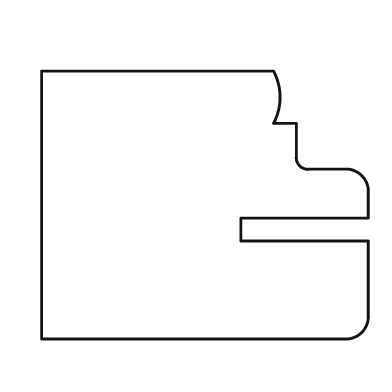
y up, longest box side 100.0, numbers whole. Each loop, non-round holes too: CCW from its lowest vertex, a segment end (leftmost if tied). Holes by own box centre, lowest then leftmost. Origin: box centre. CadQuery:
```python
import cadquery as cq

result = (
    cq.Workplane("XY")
    .moveTo(-50.0, -41.0)
    .lineTo(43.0, -41.0)
    .threePointArc((48.0, -39.0), (50.0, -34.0))
    .lineTo(50.0, -11.0)
    .lineTo(11.0, -11.0)
    .lineTo(11.0, -4.0)
    .lineTo(50.0, -4.0)
    .lineTo(50.0, 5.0)
    .threePointArc((48.0, 9.0), (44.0, 11.0))
    .lineTo(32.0, 11.0)
    .threePointArc((29.0, 12.0), (28.0, 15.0))
    .lineTo(28.0, 25.0)
    .lineTo(21.0, 25.0)
    .threePointArc((23.0, 33.0), (21.0, 41.0))
    .lineTo(-50.0, 41.0)
    .close()
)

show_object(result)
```